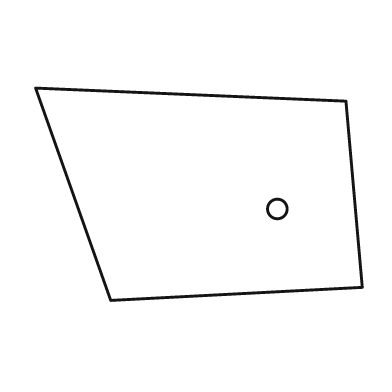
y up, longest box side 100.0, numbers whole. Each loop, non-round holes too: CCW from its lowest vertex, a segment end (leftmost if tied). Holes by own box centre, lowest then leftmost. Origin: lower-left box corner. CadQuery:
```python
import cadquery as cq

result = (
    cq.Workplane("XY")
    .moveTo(23.0, 0.0)
    .lineTo(100.0, 4.0)
    .lineTo(95.0, 61.0)
    .lineTo(0.0, 65.0)
    .close()
    .moveTo(74.0, 28.0)
    .circle(3.0)
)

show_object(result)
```